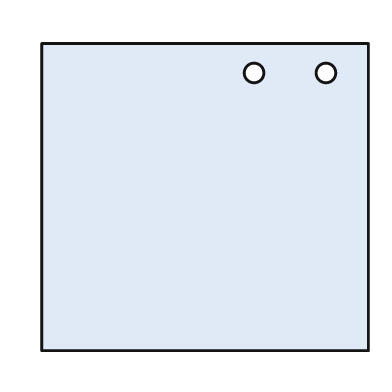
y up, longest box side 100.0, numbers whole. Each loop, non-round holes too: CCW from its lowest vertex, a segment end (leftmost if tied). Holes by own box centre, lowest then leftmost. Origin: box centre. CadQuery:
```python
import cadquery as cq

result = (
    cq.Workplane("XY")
    .moveTo(-50.0, -47.0)
    .lineTo(50.0, -47.0)
    .lineTo(50.0, 47.0)
    .lineTo(-50.0, 47.0)
    .close()
    .moveTo(15.0, 38.0)
    .circle(3.0)
    .moveTo(37.0, 38.0)
    .circle(3.0)
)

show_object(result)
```